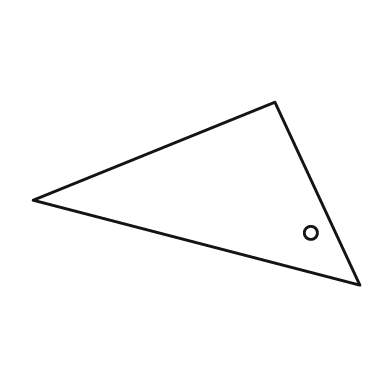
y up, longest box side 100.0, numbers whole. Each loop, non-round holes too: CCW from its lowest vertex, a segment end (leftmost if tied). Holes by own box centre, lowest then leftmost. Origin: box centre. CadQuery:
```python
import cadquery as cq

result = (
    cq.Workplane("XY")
    .moveTo(50.0, -28.0)
    .lineTo(24.0, 28.0)
    .lineTo(-50.0, -2.0)
    .close()
    .moveTo(35.0, -12.0)
    .circle(2.0)
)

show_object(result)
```